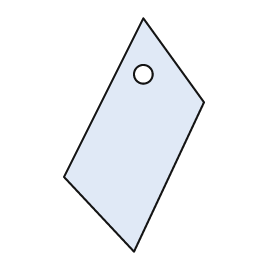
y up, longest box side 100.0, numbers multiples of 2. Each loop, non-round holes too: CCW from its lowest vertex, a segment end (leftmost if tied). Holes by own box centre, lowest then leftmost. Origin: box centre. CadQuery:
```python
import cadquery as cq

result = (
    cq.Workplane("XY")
    .moveTo(0.0, -50.0)
    .lineTo(30.0, 14.0)
    .lineTo(4.0, 50.0)
    .lineTo(-30.0, -18.0)
    .close()
    .moveTo(4.0, 26.0)
    .circle(4.0)
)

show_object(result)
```